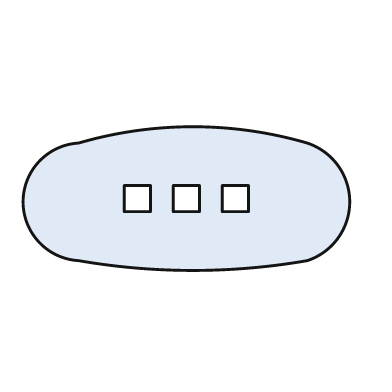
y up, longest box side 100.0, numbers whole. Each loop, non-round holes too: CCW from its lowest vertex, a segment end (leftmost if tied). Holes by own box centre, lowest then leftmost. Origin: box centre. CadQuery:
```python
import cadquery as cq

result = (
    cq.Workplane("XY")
    .moveTo(-33.0, -19.0)
    .threePointArc((2.0, -22.0), (37.0, -19.0))
    .threePointArc((50.0, -1.0), (37.0, 17.0))
    .threePointArc((2.0, 22.0), (-33.0, 17.0))
    .threePointArc((-50.0, -1.0), (-33.0, -19.0))
    .close()
    .moveTo(-19.0, -4.0)
    .lineTo(-11.0, -4.0)
    .lineTo(-11.0, 4.0)
    .lineTo(-19.0, 4.0)
    .close()
    .moveTo(-4.0, -4.0)
    .lineTo(4.0, -4.0)
    .lineTo(4.0, 4.0)
    .lineTo(-4.0, 4.0)
    .close()
    .moveTo(11.0, -4.0)
    .lineTo(19.0, -4.0)
    .lineTo(19.0, 4.0)
    .lineTo(11.0, 4.0)
    .close()
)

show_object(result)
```